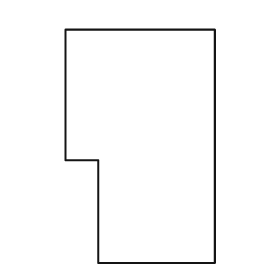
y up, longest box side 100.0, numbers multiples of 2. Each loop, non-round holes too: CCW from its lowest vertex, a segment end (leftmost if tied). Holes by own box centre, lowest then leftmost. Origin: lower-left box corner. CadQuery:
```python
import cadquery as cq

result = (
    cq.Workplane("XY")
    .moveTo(14.0, 0.0)
    .lineTo(64.0, 0.0)
    .lineTo(64.0, 100.0)
    .lineTo(0.0, 100.0)
    .lineTo(0.0, 44.0)
    .lineTo(14.0, 44.0)
    .close()
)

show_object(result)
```